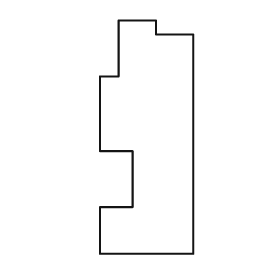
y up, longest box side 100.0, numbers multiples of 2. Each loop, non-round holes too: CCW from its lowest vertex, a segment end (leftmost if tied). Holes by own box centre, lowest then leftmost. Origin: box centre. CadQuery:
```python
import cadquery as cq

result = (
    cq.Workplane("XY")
    .moveTo(-20.0, -50.0)
    .lineTo(20.0, -50.0)
    .lineTo(20.0, 44.0)
    .lineTo(4.0, 44.0)
    .lineTo(4.0, 50.0)
    .lineTo(-12.0, 50.0)
    .lineTo(-12.0, 26.0)
    .lineTo(-20.0, 26.0)
    .lineTo(-20.0, -6.0)
    .lineTo(-6.0, -6.0)
    .lineTo(-6.0, -30.0)
    .lineTo(-20.0, -30.0)
    .close()
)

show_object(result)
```